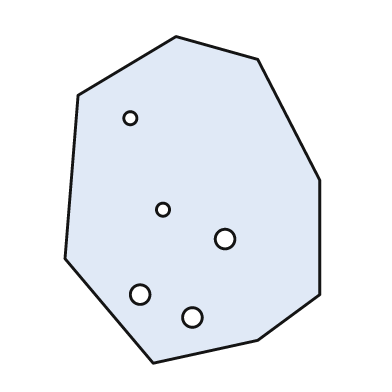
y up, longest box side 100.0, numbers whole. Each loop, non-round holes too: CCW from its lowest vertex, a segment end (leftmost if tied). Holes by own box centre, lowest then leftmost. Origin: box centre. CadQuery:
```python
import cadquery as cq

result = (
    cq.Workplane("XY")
    .moveTo(-12.0, -50.0)
    .lineTo(20.0, -43.0)
    .lineTo(39.0, -29.0)
    .lineTo(39.0, 6.0)
    .lineTo(20.0, 43.0)
    .lineTo(-5.0, 50.0)
    .lineTo(-35.0, 32.0)
    .lineTo(-39.0, -18.0)
    .close()
    .moveTo(0.0, -36.0)
    .circle(3.0)
    .moveTo(-16.0, -29.0)
    .circle(3.0)
    .moveTo(10.0, -12.0)
    .circle(3.0)
    .moveTo(-9.0, -3.0)
    .circle(2.0)
    .moveTo(-19.0, 25.0)
    .circle(2.0)
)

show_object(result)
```